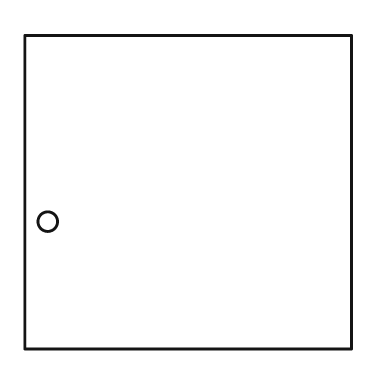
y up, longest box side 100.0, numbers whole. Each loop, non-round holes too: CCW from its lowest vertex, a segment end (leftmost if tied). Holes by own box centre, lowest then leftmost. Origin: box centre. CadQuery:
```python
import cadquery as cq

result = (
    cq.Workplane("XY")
    .moveTo(-50.0, -48.0)
    .lineTo(50.0, -48.0)
    .lineTo(50.0, 48.0)
    .lineTo(-50.0, 48.0)
    .close()
    .moveTo(-43.0, -9.0)
    .circle(3.0)
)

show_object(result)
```